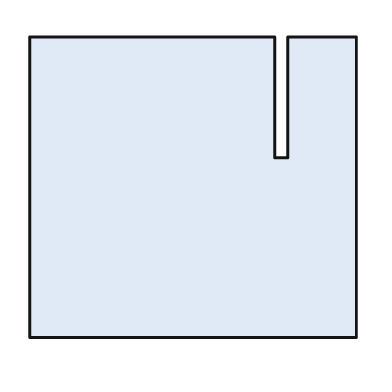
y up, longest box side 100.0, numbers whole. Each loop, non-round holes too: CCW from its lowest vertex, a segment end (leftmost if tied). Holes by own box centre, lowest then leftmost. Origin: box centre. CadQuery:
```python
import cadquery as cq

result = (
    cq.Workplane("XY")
    .moveTo(-50.0, -46.0)
    .lineTo(50.0, -46.0)
    .lineTo(50.0, 46.0)
    .lineTo(29.0, 46.0)
    .lineTo(29.0, 9.0)
    .lineTo(25.0, 9.0)
    .lineTo(25.0, 46.0)
    .lineTo(-50.0, 46.0)
    .close()
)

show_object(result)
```